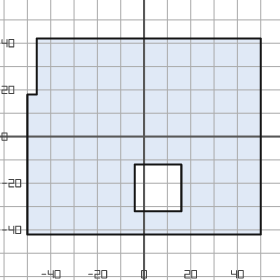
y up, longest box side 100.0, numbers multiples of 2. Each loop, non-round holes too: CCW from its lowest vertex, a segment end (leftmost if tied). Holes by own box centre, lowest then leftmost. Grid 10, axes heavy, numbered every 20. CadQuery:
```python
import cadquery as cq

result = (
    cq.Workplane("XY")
    .moveTo(-50.0, -42.0)
    .lineTo(50.0, -42.0)
    .lineTo(50.0, 42.0)
    .lineTo(-46.0, 42.0)
    .lineTo(-46.0, 18.0)
    .lineTo(-50.0, 18.0)
    .close()
    .moveTo(-4.0, -32.0)
    .lineTo(16.0, -32.0)
    .lineTo(16.0, -12.0)
    .lineTo(-4.0, -12.0)
    .close()
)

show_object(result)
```